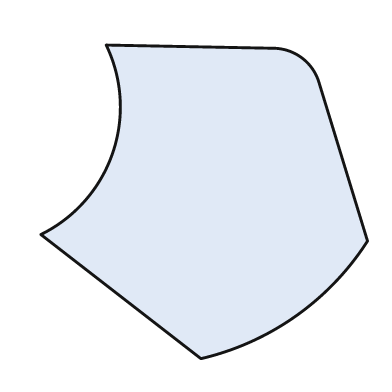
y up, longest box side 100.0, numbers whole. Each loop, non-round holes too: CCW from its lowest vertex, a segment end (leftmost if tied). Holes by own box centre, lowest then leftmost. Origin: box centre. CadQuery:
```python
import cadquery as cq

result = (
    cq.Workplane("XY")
    .moveTo(-1.0, -48.0)
    .threePointArc((28.0, -35.0), (50.0, -12.0))
    .lineTo(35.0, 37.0)
    .threePointArc((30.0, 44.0), (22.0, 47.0))
    .lineTo(-30.0, 48.0)
    .threePointArc((-28.0, 15.0), (-50.0, -10.0))
    .close()
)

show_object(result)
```